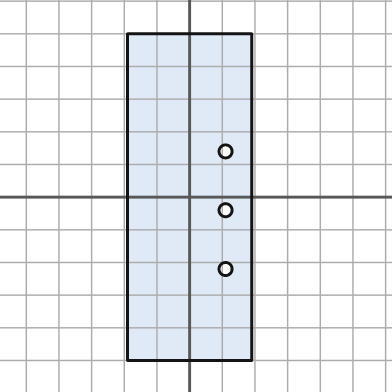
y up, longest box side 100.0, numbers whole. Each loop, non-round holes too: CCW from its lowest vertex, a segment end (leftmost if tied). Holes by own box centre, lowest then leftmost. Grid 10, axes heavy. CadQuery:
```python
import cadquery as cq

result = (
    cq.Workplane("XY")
    .moveTo(-19.0, -50.0)
    .lineTo(19.0, -50.0)
    .lineTo(19.0, 50.0)
    .lineTo(-19.0, 50.0)
    .close()
    .moveTo(11.0, -22.0)
    .circle(2.0)
    .moveTo(11.0, -4.0)
    .circle(2.0)
    .moveTo(11.0, 14.0)
    .circle(2.0)
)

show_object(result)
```